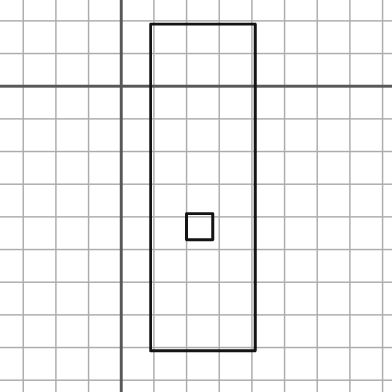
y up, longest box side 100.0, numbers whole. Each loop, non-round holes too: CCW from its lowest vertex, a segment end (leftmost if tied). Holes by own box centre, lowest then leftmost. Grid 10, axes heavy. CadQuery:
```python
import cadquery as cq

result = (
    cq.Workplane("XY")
    .moveTo(9.0, -81.0)
    .lineTo(41.0, -81.0)
    .lineTo(41.0, 19.0)
    .lineTo(9.0, 19.0)
    .close()
    .moveTo(20.0, -47.0)
    .lineTo(28.0, -47.0)
    .lineTo(28.0, -39.0)
    .lineTo(20.0, -39.0)
    .close()
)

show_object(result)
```